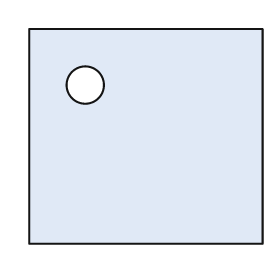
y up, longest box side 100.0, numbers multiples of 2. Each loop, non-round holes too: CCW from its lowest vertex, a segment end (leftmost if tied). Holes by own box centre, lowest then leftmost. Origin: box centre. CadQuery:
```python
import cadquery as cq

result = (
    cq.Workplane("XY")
    .moveTo(-50.0, -46.0)
    .lineTo(50.0, -46.0)
    .lineTo(50.0, 46.0)
    .lineTo(-50.0, 46.0)
    .close()
    .moveTo(-26.0, 22.0)
    .circle(8.0)
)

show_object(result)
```